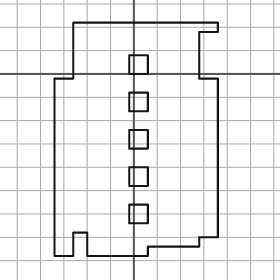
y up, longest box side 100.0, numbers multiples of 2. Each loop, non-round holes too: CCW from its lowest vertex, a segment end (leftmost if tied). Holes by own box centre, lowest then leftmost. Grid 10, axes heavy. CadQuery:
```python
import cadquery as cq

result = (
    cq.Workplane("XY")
    .moveTo(-34.0, -78.0)
    .lineTo(-26.0, -78.0)
    .lineTo(-26.0, -68.0)
    .lineTo(-20.0, -68.0)
    .lineTo(-20.0, -78.0)
    .lineTo(6.0, -78.0)
    .lineTo(6.0, -74.0)
    .lineTo(28.0, -74.0)
    .lineTo(28.0, -70.0)
    .lineTo(36.0, -70.0)
    .lineTo(36.0, -2.0)
    .lineTo(28.0, -2.0)
    .lineTo(28.0, 18.0)
    .lineTo(36.0, 18.0)
    .lineTo(36.0, 22.0)
    .lineTo(-26.0, 22.0)
    .lineTo(-26.0, -2.0)
    .lineTo(-34.0, -2.0)
    .close()
    .moveTo(-2.0, -64.0)
    .lineTo(6.0, -64.0)
    .lineTo(6.0, -56.0)
    .lineTo(-2.0, -56.0)
    .close()
    .moveTo(-2.0, -48.0)
    .lineTo(6.0, -48.0)
    .lineTo(6.0, -40.0)
    .lineTo(-2.0, -40.0)
    .close()
    .moveTo(-2.0, -32.0)
    .lineTo(6.0, -32.0)
    .lineTo(6.0, -24.0)
    .lineTo(-2.0, -24.0)
    .close()
    .moveTo(-2.0, -16.0)
    .lineTo(6.0, -16.0)
    .lineTo(6.0, -8.0)
    .lineTo(-2.0, -8.0)
    .close()
    .moveTo(-2.0, 0.0)
    .lineTo(6.0, 0.0)
    .lineTo(6.0, 8.0)
    .lineTo(-2.0, 8.0)
    .close()
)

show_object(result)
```